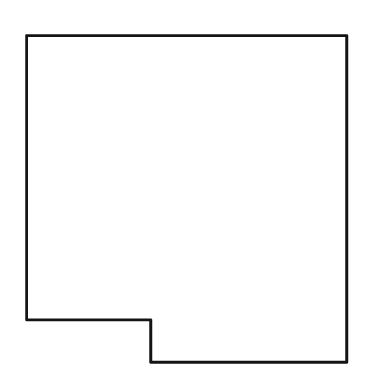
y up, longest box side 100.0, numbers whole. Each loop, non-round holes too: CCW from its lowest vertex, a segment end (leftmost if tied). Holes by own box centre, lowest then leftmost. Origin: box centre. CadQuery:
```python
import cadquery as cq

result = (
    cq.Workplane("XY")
    .moveTo(-11.0, -50.0)
    .lineTo(49.0, -50.0)
    .lineTo(49.0, 50.0)
    .lineTo(-49.0, 50.0)
    .lineTo(-49.0, -37.0)
    .lineTo(-11.0, -37.0)
    .close()
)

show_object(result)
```